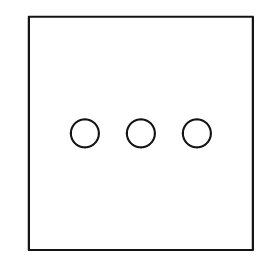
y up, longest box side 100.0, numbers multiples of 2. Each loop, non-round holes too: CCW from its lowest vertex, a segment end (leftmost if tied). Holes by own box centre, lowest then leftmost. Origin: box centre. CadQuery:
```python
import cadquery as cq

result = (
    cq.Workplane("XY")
    .moveTo(-48.0, -50.0)
    .lineTo(48.0, -50.0)
    .lineTo(48.0, 50.0)
    .lineTo(-48.0, 50.0)
    .close()
    .moveTo(-24.0, 0.0)
    .circle(6.0)
    .moveTo(0.0, 0.0)
    .circle(6.0)
    .moveTo(24.0, 0.0)
    .circle(6.0)
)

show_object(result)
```